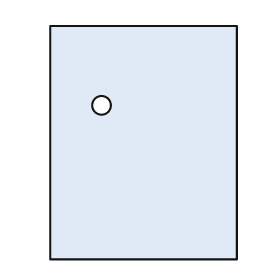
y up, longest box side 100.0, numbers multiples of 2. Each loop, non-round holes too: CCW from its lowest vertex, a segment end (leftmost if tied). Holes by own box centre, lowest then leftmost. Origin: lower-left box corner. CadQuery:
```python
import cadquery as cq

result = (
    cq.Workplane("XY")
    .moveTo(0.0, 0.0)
    .lineTo(80.0, 0.0)
    .lineTo(80.0, 100.0)
    .lineTo(0.0, 100.0)
    .close()
    .moveTo(22.0, 66.0)
    .circle(4.0)
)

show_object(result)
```